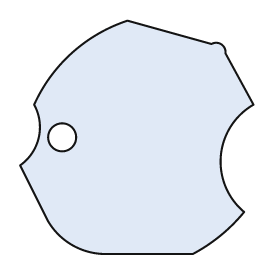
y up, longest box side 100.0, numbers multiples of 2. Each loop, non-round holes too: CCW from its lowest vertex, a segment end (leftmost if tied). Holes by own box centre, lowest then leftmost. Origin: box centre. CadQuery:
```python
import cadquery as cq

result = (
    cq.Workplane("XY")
    .moveTo(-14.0, -50.0)
    .lineTo(24.0, -50.0)
    .threePointArc((36.0, -42.0), (46.0, -32.0))
    .threePointArc((36.0, -8.0), (50.0, 14.0))
    .lineTo(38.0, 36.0)
    .threePointArc((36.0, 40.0), (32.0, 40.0))
    .lineTo(-4.0, 50.0)
    .threePointArc((-28.0, 36.0), (-44.0, 14.0))
    .threePointArc((-42.0, 0.0), (-50.0, -12.0))
    .lineTo(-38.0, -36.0)
    .threePointArc((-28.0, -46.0), (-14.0, -50.0))
    .close()
    .moveTo(-32.0, 0.0)
    .circle(6.0)
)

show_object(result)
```